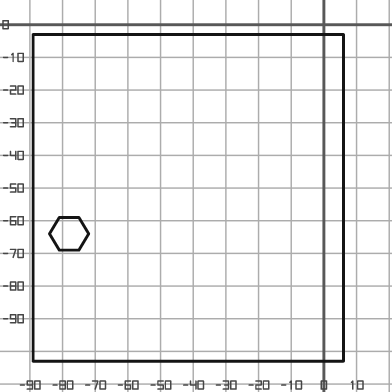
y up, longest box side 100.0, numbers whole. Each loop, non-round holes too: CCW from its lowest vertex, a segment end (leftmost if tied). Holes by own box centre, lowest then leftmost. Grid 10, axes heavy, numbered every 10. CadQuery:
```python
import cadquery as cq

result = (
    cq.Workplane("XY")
    .moveTo(-89.0, -103.0)
    .lineTo(6.0, -103.0)
    .lineTo(6.0, -3.0)
    .lineTo(-89.0, -3.0)
    .close()
    .moveTo(-81.0, -69.0)
    .lineTo(-75.0, -69.0)
    .lineTo(-72.0, -64.0)
    .lineTo(-75.0, -59.0)
    .lineTo(-81.0, -59.0)
    .lineTo(-84.0, -64.0)
    .close()
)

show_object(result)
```